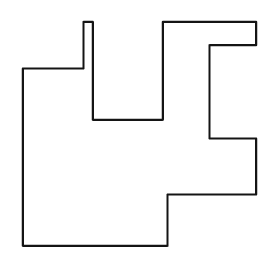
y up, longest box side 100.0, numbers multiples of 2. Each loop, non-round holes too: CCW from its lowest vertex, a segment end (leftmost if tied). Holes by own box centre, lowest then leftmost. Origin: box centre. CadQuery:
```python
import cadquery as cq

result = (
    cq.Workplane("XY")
    .moveTo(-50.0, -48.0)
    .lineTo(12.0, -48.0)
    .lineTo(12.0, -26.0)
    .lineTo(50.0, -26.0)
    .lineTo(50.0, -2.0)
    .lineTo(30.0, -2.0)
    .lineTo(30.0, 38.0)
    .lineTo(50.0, 38.0)
    .lineTo(50.0, 48.0)
    .lineTo(10.0, 48.0)
    .lineTo(10.0, 6.0)
    .lineTo(-20.0, 6.0)
    .lineTo(-20.0, 48.0)
    .lineTo(-24.0, 48.0)
    .lineTo(-24.0, 28.0)
    .lineTo(-50.0, 28.0)
    .close()
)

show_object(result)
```